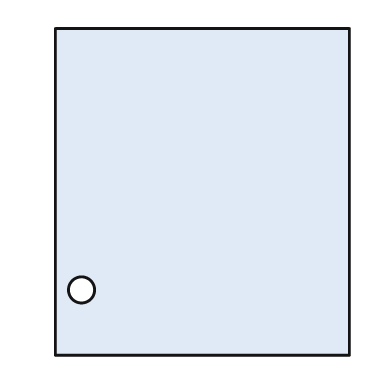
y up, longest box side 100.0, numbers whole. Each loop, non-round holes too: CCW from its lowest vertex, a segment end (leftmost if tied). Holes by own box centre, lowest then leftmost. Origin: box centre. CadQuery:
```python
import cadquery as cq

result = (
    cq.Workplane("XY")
    .moveTo(-45.0, -50.0)
    .lineTo(45.0, -50.0)
    .lineTo(45.0, 50.0)
    .lineTo(-45.0, 50.0)
    .close()
    .moveTo(-37.0, -30.0)
    .circle(4.0)
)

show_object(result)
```